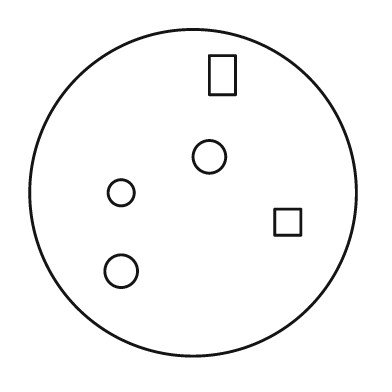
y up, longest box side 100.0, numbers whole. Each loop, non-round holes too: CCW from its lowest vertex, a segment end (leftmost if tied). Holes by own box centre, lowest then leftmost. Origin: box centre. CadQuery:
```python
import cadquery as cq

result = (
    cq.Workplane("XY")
    .moveTo(0.0, 0.0)
    .circle(50.0)
    .moveTo(-22.0, -24.0)
    .circle(5.0)
    .moveTo(25.0, -13.0)
    .lineTo(33.0, -13.0)
    .lineTo(33.0, -5.0)
    .lineTo(25.0, -5.0)
    .close()
    .moveTo(-22.0, 0.0)
    .circle(4.0)
    .moveTo(5.0, 11.0)
    .circle(5.0)
    .moveTo(5.0, 30.0)
    .lineTo(13.0, 30.0)
    .lineTo(13.0, 42.0)
    .lineTo(5.0, 42.0)
    .close()
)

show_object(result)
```